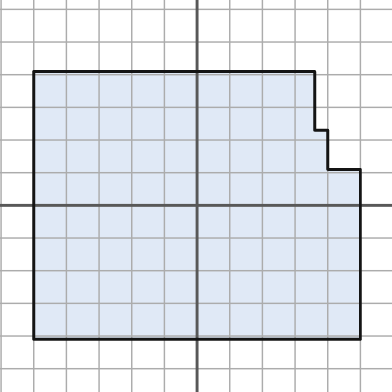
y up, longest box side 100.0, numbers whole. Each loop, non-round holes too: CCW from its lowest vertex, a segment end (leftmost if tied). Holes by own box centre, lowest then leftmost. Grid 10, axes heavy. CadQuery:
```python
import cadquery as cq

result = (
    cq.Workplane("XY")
    .moveTo(-50.0, -41.0)
    .lineTo(50.0, -41.0)
    .lineTo(50.0, 11.0)
    .lineTo(40.0, 11.0)
    .lineTo(40.0, 23.0)
    .lineTo(36.0, 23.0)
    .lineTo(36.0, 41.0)
    .lineTo(-50.0, 41.0)
    .close()
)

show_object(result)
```